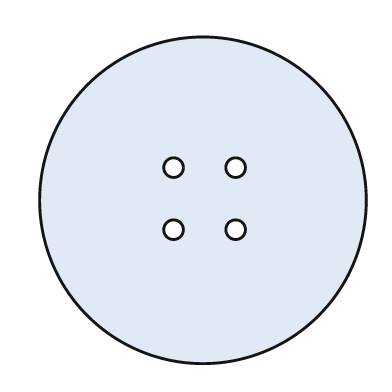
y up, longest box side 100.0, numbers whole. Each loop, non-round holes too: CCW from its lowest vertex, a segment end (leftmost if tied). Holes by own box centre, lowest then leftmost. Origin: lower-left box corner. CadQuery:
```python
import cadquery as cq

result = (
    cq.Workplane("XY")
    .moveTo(50.0, 50.0)
    .circle(50.0)
    .moveTo(41.0, 41.0)
    .circle(3.0)
    .moveTo(60.0, 41.0)
    .circle(3.0)
    .moveTo(41.0, 60.0)
    .circle(3.0)
    .moveTo(60.0, 60.0)
    .circle(3.0)
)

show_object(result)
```